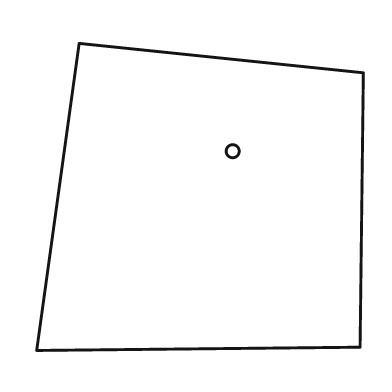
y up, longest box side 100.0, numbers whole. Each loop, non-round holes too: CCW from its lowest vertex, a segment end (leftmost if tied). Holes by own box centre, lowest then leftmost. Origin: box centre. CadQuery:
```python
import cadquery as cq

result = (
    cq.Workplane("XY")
    .moveTo(-50.0, -47.0)
    .lineTo(49.0, -46.0)
    .lineTo(50.0, 38.0)
    .lineTo(-37.0, 47.0)
    .close()
    .moveTo(10.0, 14.0)
    .circle(2.0)
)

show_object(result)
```